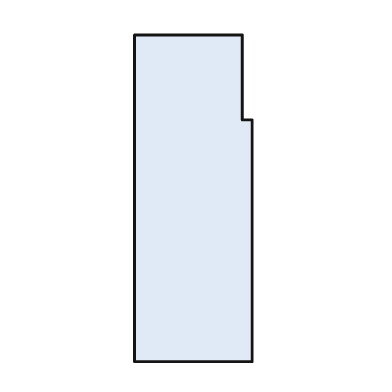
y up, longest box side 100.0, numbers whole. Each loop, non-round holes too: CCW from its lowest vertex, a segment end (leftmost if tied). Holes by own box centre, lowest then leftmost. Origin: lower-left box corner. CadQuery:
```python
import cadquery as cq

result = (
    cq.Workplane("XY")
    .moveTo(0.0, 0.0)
    .lineTo(36.0, 0.0)
    .lineTo(36.0, 74.0)
    .lineTo(33.0, 74.0)
    .lineTo(33.0, 100.0)
    .lineTo(0.0, 100.0)
    .close()
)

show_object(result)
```